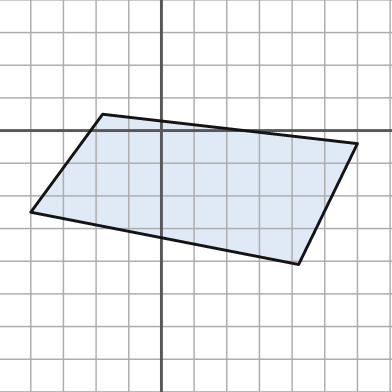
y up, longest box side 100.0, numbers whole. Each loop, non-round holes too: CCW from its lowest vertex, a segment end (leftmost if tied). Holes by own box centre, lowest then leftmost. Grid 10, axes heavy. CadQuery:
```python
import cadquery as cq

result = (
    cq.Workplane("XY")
    .moveTo(42.0, -41.0)
    .lineTo(60.0, -4.0)
    .lineTo(-18.0, 5.0)
    .lineTo(-40.0, -25.0)
    .close()
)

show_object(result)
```